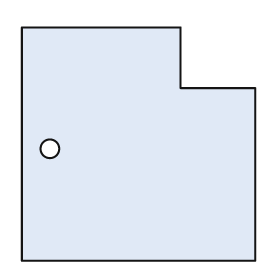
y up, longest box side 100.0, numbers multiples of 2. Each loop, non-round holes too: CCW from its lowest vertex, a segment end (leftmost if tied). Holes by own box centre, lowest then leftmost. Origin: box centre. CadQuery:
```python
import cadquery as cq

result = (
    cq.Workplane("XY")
    .moveTo(-50.0, -50.0)
    .lineTo(50.0, -50.0)
    .lineTo(50.0, 24.0)
    .lineTo(18.0, 24.0)
    .lineTo(18.0, 50.0)
    .lineTo(-50.0, 50.0)
    .close()
    .moveTo(-38.0, -2.0)
    .circle(4.0)
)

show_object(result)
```